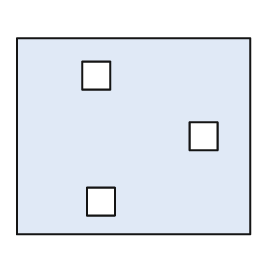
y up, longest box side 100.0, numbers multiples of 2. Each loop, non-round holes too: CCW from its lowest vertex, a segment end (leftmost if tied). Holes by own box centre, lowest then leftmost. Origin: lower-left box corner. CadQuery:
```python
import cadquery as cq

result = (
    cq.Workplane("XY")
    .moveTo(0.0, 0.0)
    .lineTo(100.0, 0.0)
    .lineTo(100.0, 84.0)
    .lineTo(0.0, 84.0)
    .close()
    .moveTo(30.0, 8.0)
    .lineTo(42.0, 8.0)
    .lineTo(42.0, 20.0)
    .lineTo(30.0, 20.0)
    .close()
    .moveTo(74.0, 36.0)
    .lineTo(86.0, 36.0)
    .lineTo(86.0, 48.0)
    .lineTo(74.0, 48.0)
    .close()
    .moveTo(28.0, 62.0)
    .lineTo(40.0, 62.0)
    .lineTo(40.0, 74.0)
    .lineTo(28.0, 74.0)
    .close()
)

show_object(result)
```